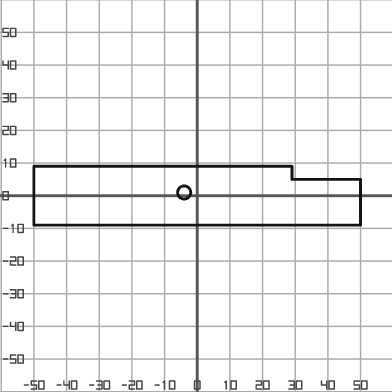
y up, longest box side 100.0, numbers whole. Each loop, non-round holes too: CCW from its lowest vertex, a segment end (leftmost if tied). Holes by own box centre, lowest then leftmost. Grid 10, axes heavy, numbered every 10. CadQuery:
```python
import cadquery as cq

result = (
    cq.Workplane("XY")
    .moveTo(-50.0, -9.0)
    .lineTo(50.0, -9.0)
    .lineTo(50.0, 5.0)
    .lineTo(29.0, 5.0)
    .lineTo(29.0, 9.0)
    .lineTo(-50.0, 9.0)
    .close()
    .moveTo(-4.0, 1.0)
    .circle(2.0)
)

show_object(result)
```